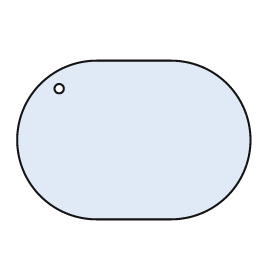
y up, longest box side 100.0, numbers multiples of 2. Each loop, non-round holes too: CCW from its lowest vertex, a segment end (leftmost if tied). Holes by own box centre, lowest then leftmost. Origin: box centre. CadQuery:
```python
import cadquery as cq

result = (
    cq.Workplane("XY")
    .moveTo(-16.0, -34.0)
    .lineTo(16.0, -34.0)
    .threePointArc((50.0, 0.0), (16.0, 34.0))
    .lineTo(-16.0, 34.0)
    .threePointArc((-50.0, 0.0), (-16.0, -34.0))
    .close()
    .moveTo(-32.0, 22.0)
    .circle(2.0)
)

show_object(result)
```